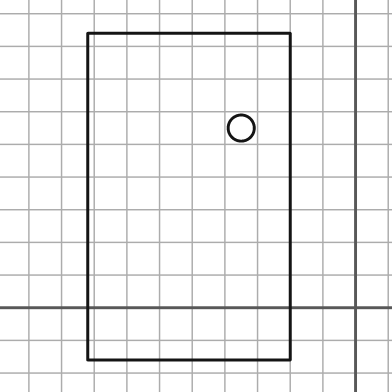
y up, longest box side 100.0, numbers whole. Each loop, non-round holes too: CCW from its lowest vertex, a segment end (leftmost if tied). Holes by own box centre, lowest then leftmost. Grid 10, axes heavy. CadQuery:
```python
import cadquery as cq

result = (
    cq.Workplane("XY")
    .moveTo(-82.0, -16.0)
    .lineTo(-20.0, -16.0)
    .lineTo(-20.0, 84.0)
    .lineTo(-82.0, 84.0)
    .close()
    .moveTo(-35.0, 55.0)
    .circle(4.0)
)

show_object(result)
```